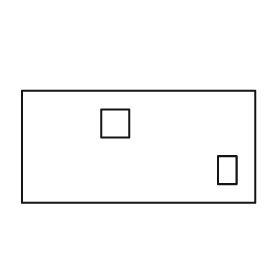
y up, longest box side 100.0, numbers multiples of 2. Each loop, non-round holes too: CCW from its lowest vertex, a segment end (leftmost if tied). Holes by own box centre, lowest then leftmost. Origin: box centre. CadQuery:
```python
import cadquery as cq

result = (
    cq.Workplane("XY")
    .moveTo(-50.0, -24.0)
    .lineTo(50.0, -24.0)
    .lineTo(50.0, 24.0)
    .lineTo(-50.0, 24.0)
    .close()
    .moveTo(34.0, -16.0)
    .lineTo(42.0, -16.0)
    .lineTo(42.0, -4.0)
    .lineTo(34.0, -4.0)
    .close()
    .moveTo(-16.0, 4.0)
    .lineTo(-4.0, 4.0)
    .lineTo(-4.0, 16.0)
    .lineTo(-16.0, 16.0)
    .close()
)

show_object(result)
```